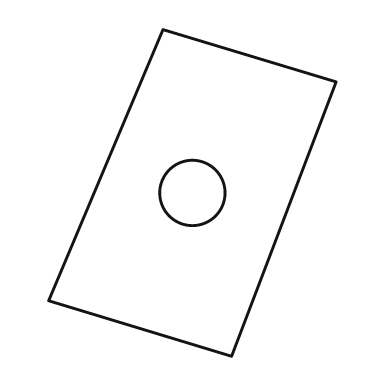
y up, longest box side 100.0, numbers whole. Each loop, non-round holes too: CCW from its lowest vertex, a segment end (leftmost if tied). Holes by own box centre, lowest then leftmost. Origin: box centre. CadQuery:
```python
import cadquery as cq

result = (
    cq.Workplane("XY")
    .moveTo(12.0, -50.0)
    .lineTo(44.0, 34.0)
    .lineTo(-9.0, 50.0)
    .lineTo(-44.0, -33.0)
    .close()
    .moveTo(0.0, 0.0)
    .circle(10.0)
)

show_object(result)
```